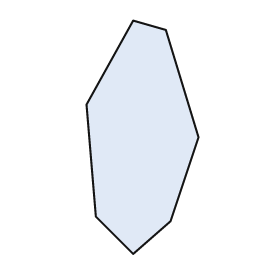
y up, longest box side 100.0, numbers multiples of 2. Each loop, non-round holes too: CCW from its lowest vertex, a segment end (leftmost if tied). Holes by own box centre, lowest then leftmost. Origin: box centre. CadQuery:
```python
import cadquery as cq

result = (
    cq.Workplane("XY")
    .moveTo(-4.0, -50.0)
    .lineTo(12.0, -36.0)
    .lineTo(24.0, 0.0)
    .lineTo(10.0, 46.0)
    .lineTo(-4.0, 50.0)
    .lineTo(-24.0, 14.0)
    .lineTo(-20.0, -34.0)
    .close()
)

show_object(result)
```